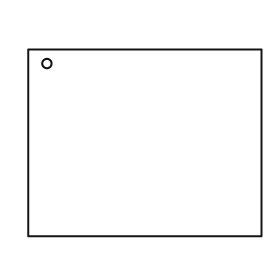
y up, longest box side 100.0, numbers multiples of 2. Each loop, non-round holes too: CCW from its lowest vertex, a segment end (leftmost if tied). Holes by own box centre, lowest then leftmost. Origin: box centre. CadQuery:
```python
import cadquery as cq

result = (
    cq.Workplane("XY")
    .moveTo(-50.0, -40.0)
    .lineTo(50.0, -40.0)
    .lineTo(50.0, 40.0)
    .lineTo(-50.0, 40.0)
    .close()
    .moveTo(-42.0, 34.0)
    .circle(2.0)
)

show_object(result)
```